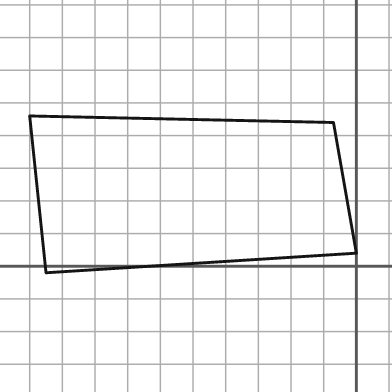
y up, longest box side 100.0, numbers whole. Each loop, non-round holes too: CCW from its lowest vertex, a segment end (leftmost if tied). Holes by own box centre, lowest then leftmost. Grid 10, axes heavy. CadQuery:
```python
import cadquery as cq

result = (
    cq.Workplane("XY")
    .moveTo(-95.0, -2.0)
    .lineTo(0.0, 4.0)
    .lineTo(-7.0, 44.0)
    .lineTo(-100.0, 46.0)
    .close()
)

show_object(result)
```